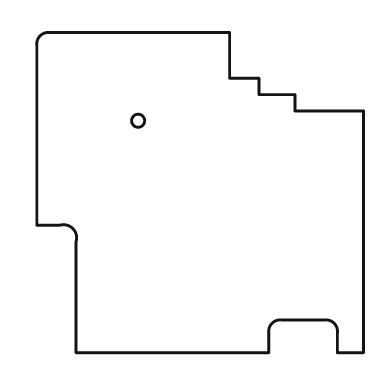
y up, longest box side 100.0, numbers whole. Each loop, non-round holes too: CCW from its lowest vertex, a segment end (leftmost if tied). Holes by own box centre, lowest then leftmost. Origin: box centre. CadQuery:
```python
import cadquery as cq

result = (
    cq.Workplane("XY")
    .moveTo(-38.0, -49.0)
    .lineTo(21.0, -49.0)
    .lineTo(21.0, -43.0)
    .threePointArc((22.0, -40.0), (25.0, -39.0))
    .lineTo(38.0, -39.0)
    .threePointArc((41.0, -40.0), (42.0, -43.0))
    .lineTo(42.0, -49.0)
    .lineTo(50.0, -49.0)
    .lineTo(50.0, 25.0)
    .lineTo(29.0, 25.0)
    .lineTo(29.0, 30.0)
    .lineTo(18.0, 30.0)
    .lineTo(18.0, 35.0)
    .lineTo(9.0, 35.0)
    .lineTo(9.0, 49.0)
    .lineTo(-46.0, 49.0)
    .threePointArc((-49.0, 48.0), (-50.0, 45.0))
    .lineTo(-50.0, -10.0)
    .lineTo(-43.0, -10.0)
    .threePointArc((-39.0, -11.0), (-38.0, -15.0))
    .close()
    .moveTo(-19.0, 22.0)
    .circle(2.0)
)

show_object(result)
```